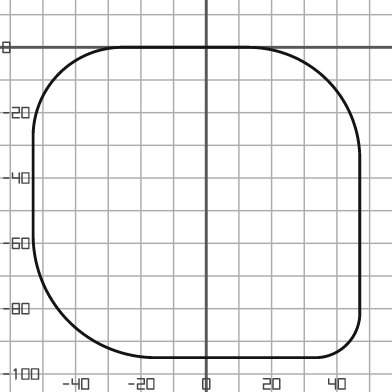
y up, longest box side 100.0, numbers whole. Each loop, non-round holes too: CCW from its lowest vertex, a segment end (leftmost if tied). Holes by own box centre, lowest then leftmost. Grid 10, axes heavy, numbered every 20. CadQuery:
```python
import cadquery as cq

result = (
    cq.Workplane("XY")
    .moveTo(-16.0, -95.0)
    .lineTo(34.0, -95.0)
    .threePointArc((43.0, -91.0), (47.0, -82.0))
    .lineTo(47.0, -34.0)
    .threePointArc((37.0, -10.0), (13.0, 0.0))
    .lineTo(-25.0, 0.0)
    .threePointArc((-45.0, -8.0), (-53.0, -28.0))
    .lineTo(-53.0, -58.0)
    .threePointArc((-42.0, -84.0), (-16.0, -95.0))
    .close()
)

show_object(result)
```